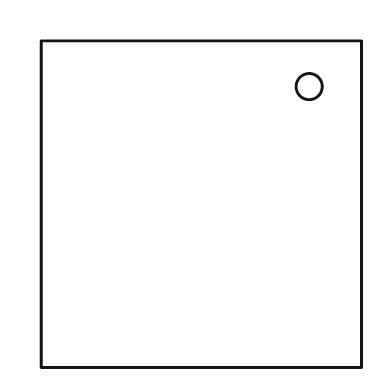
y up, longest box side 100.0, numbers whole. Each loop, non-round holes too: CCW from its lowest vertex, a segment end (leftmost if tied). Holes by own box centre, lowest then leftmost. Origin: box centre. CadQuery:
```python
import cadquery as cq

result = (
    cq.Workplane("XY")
    .moveTo(-49.0, -50.0)
    .lineTo(49.0, -50.0)
    .lineTo(49.0, 50.0)
    .lineTo(-49.0, 50.0)
    .close()
    .moveTo(33.0, 36.0)
    .circle(4.0)
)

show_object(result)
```